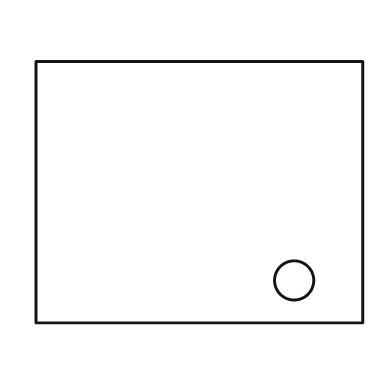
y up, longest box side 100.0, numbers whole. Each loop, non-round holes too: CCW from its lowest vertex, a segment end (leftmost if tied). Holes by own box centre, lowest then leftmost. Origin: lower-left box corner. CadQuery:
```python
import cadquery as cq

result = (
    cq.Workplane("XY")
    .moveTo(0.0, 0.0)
    .lineTo(100.0, 0.0)
    .lineTo(100.0, 80.0)
    .lineTo(0.0, 80.0)
    .close()
    .moveTo(79.0, 13.0)
    .circle(6.0)
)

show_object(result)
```